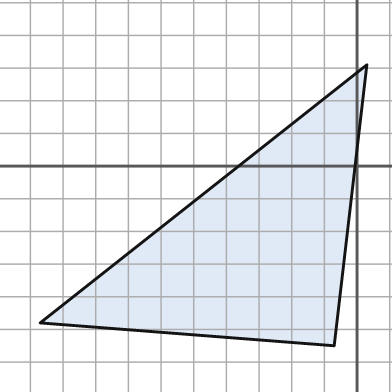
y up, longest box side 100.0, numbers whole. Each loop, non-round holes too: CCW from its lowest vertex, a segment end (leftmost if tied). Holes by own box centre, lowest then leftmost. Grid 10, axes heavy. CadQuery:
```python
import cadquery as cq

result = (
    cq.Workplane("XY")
    .moveTo(-7.0, -55.0)
    .lineTo(3.0, 31.0)
    .lineTo(-97.0, -48.0)
    .close()
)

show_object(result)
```